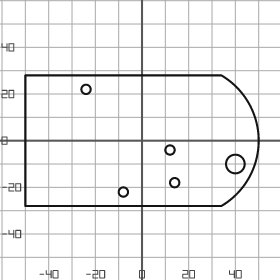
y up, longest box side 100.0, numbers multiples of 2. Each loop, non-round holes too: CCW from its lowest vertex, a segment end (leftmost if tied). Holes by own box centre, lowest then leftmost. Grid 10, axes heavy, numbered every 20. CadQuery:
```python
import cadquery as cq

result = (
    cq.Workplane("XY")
    .moveTo(-50.0, -28.0)
    .lineTo(34.0, -28.0)
    .threePointArc((50.0, 0.0), (34.0, 28.0))
    .lineTo(-50.0, 28.0)
    .close()
    .moveTo(-8.0, -22.0)
    .circle(2.0)
    .moveTo(14.0, -18.0)
    .circle(2.0)
    .moveTo(40.0, -10.0)
    .circle(4.0)
    .moveTo(12.0, -4.0)
    .circle(2.0)
    .moveTo(-24.0, 22.0)
    .circle(2.0)
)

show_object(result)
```